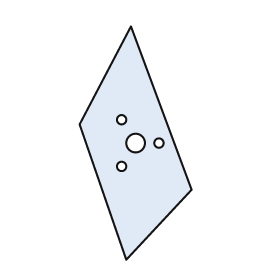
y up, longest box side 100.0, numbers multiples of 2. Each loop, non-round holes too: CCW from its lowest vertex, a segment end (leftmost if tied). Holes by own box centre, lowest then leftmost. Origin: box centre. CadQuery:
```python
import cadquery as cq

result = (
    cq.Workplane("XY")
    .moveTo(-4.0, -50.0)
    .lineTo(24.0, -20.0)
    .lineTo(-2.0, 50.0)
    .lineTo(-24.0, 8.0)
    .close()
    .moveTo(-6.0, -10.0)
    .circle(2.0)
    .moveTo(0.0, 0.0)
    .circle(4.0)
    .moveTo(10.0, 0.0)
    .circle(2.0)
    .moveTo(-6.0, 10.0)
    .circle(2.0)
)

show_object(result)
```